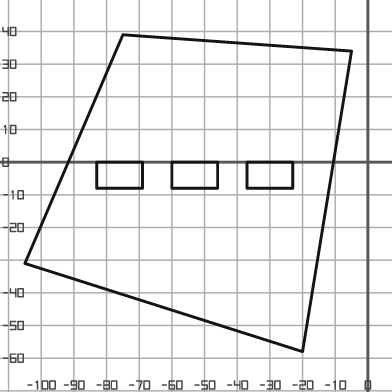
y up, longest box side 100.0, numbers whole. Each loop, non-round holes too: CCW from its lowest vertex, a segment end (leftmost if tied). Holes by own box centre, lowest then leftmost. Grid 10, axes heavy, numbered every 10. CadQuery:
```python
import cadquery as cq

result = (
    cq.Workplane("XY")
    .moveTo(-20.0, -58.0)
    .lineTo(-5.0, 34.0)
    .lineTo(-75.0, 39.0)
    .lineTo(-105.0, -31.0)
    .close()
    .moveTo(-83.0, -8.0)
    .lineTo(-69.0, -8.0)
    .lineTo(-69.0, 0.0)
    .lineTo(-83.0, 0.0)
    .close()
    .moveTo(-60.0, -8.0)
    .lineTo(-46.0, -8.0)
    .lineTo(-46.0, 0.0)
    .lineTo(-60.0, 0.0)
    .close()
    .moveTo(-37.0, -8.0)
    .lineTo(-23.0, -8.0)
    .lineTo(-23.0, 0.0)
    .lineTo(-37.0, 0.0)
    .close()
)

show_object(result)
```